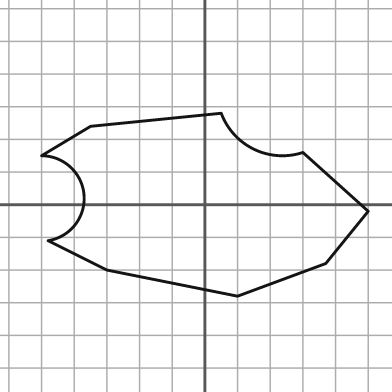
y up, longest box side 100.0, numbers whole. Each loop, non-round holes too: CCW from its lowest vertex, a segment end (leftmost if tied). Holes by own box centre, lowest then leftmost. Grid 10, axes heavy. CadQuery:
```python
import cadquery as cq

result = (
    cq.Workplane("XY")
    .moveTo(10.0, -28.0)
    .lineTo(37.0, -18.0)
    .lineTo(50.0, -2.0)
    .lineTo(30.0, 16.0)
    .threePointArc((15.0, 17.0), (5.0, 28.0))
    .lineTo(-35.0, 24.0)
    .lineTo(-50.0, 15.0)
    .threePointArc((-37.0, 3.0), (-48.0, -11.0))
    .lineTo(-30.0, -20.0)
    .close()
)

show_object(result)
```